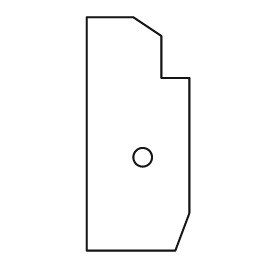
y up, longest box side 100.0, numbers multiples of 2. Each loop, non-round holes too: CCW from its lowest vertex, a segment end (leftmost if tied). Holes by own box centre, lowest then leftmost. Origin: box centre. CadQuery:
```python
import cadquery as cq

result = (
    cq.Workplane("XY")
    .moveTo(-22.0, -50.0)
    .lineTo(16.0, -50.0)
    .lineTo(22.0, -34.0)
    .lineTo(22.0, 24.0)
    .lineTo(10.0, 24.0)
    .lineTo(10.0, 42.0)
    .lineTo(-2.0, 50.0)
    .lineTo(-22.0, 50.0)
    .close()
    .moveTo(2.0, -10.0)
    .circle(4.0)
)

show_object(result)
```